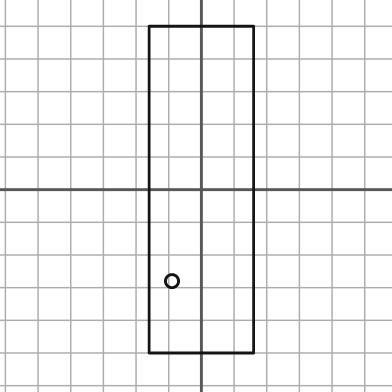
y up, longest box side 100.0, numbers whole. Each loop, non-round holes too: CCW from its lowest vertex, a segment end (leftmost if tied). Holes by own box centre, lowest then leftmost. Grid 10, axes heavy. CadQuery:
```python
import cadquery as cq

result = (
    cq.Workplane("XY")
    .moveTo(-16.0, -50.0)
    .lineTo(16.0, -50.0)
    .lineTo(16.0, 50.0)
    .lineTo(-16.0, 50.0)
    .close()
    .moveTo(-9.0, -28.0)
    .circle(2.0)
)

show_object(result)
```